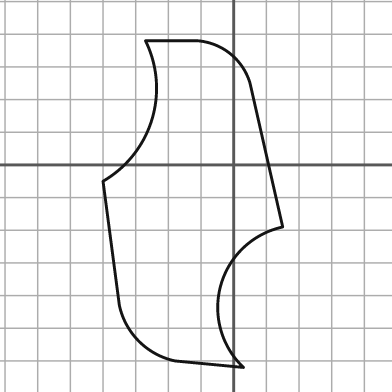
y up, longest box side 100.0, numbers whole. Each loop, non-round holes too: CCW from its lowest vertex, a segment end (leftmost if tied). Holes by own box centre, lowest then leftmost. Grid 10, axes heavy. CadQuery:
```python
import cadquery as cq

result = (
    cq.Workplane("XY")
    .moveTo(3.0, -62.0)
    .threePointArc((-4.0, -37.0), (15.0, -19.0))
    .lineTo(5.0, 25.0)
    .threePointArc((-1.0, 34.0), (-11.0, 38.0))
    .lineTo(-27.0, 38.0)
    .threePointArc((-25.0, 14.0), (-40.0, -5.0))
    .lineTo(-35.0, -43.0)
    .threePointArc((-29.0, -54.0), (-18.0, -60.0))
    .close()
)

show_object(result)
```